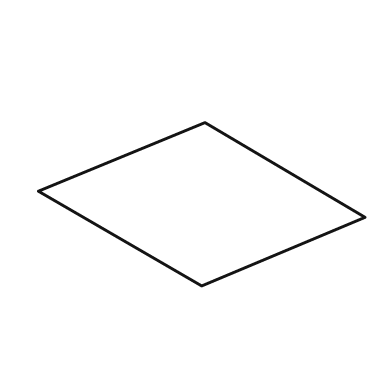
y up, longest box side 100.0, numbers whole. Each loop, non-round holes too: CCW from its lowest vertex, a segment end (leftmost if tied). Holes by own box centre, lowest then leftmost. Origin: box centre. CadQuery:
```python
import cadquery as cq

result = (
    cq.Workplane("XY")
    .moveTo(0.0, -25.0)
    .lineTo(50.0, -4.0)
    .lineTo(1.0, 25.0)
    .lineTo(-50.0, 4.0)
    .close()
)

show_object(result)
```